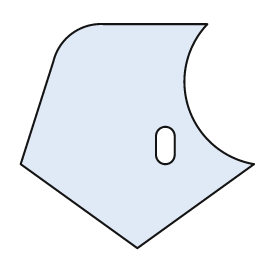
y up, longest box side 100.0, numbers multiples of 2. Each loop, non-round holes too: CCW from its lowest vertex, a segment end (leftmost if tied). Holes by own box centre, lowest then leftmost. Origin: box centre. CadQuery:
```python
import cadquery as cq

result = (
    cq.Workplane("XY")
    .moveTo(0.0, -48.0)
    .lineTo(50.0, -12.0)
    .threePointArc((22.0, 12.0), (30.0, 48.0))
    .lineTo(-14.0, 48.0)
    .threePointArc((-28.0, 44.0), (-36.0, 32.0))
    .lineTo(-50.0, -12.0)
    .close()
    .moveTo(8.0, -8.0)
    .threePointArc((12.0, -12.0), (16.0, -8.0))
    .lineTo(16.0, 0.0)
    .threePointArc((12.0, 4.0), (8.0, 0.0))
    .close()
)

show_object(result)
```